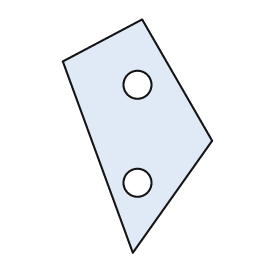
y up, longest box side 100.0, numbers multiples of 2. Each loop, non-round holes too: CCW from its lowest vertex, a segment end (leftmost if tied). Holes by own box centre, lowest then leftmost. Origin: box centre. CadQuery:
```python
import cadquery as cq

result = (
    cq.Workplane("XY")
    .moveTo(-2.0, -50.0)
    .lineTo(32.0, -2.0)
    .lineTo(2.0, 50.0)
    .lineTo(-32.0, 32.0)
    .close()
    .moveTo(0.0, -20.0)
    .circle(6.0)
    .moveTo(0.0, 22.0)
    .circle(6.0)
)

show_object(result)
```